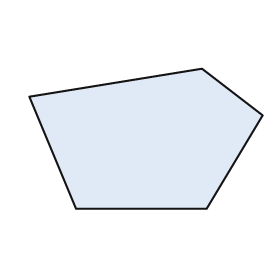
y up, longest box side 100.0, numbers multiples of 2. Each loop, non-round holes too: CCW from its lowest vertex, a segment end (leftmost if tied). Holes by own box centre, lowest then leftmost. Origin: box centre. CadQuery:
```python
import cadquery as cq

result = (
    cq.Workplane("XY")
    .moveTo(-30.0, -30.0)
    .lineTo(26.0, -30.0)
    .lineTo(50.0, 10.0)
    .lineTo(24.0, 30.0)
    .lineTo(-50.0, 18.0)
    .close()
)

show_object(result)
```